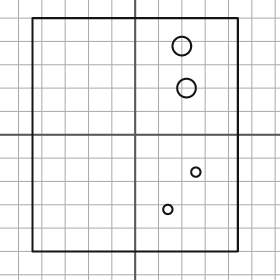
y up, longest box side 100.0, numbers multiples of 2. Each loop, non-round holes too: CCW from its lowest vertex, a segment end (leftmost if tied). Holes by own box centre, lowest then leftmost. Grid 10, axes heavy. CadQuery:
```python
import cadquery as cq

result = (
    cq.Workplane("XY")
    .moveTo(-44.0, -50.0)
    .lineTo(44.0, -50.0)
    .lineTo(44.0, 50.0)
    .lineTo(-44.0, 50.0)
    .close()
    .moveTo(14.0, -32.0)
    .circle(2.0)
    .moveTo(26.0, -16.0)
    .circle(2.0)
    .moveTo(22.0, 20.0)
    .circle(4.0)
    .moveTo(20.0, 38.0)
    .circle(4.0)
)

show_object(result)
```